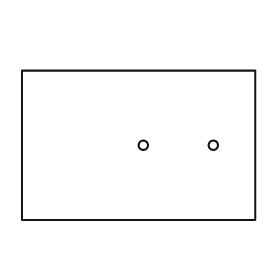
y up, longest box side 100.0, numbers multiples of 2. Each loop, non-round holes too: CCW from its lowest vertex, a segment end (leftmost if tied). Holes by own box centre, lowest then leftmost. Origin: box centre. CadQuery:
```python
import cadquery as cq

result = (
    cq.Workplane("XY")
    .moveTo(-50.0, -32.0)
    .lineTo(50.0, -32.0)
    .lineTo(50.0, 32.0)
    .lineTo(-50.0, 32.0)
    .close()
    .moveTo(2.0, 0.0)
    .circle(2.0)
    .moveTo(32.0, 0.0)
    .circle(2.0)
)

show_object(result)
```